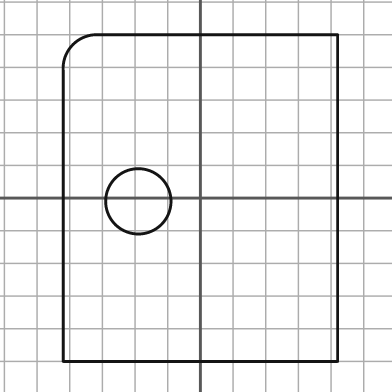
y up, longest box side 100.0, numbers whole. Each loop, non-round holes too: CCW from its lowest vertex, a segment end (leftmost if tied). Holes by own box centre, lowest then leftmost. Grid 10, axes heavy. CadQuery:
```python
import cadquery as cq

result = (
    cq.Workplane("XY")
    .moveTo(-42.0, -50.0)
    .lineTo(42.0, -50.0)
    .lineTo(42.0, 50.0)
    .lineTo(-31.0, 50.0)
    .threePointArc((-39.0, 47.0), (-42.0, 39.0))
    .close()
    .moveTo(-19.0, -1.0)
    .circle(10.0)
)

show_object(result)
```